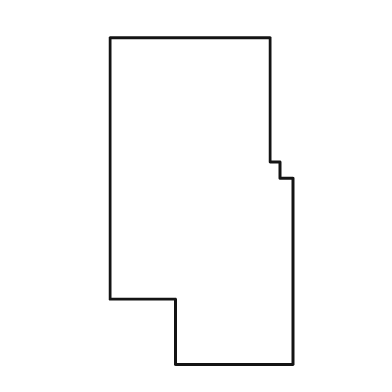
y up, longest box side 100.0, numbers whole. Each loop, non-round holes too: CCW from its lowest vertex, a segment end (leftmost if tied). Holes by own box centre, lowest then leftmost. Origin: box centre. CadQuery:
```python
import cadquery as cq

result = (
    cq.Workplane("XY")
    .moveTo(-8.0, -50.0)
    .lineTo(28.0, -50.0)
    .lineTo(28.0, 7.0)
    .lineTo(24.0, 7.0)
    .lineTo(24.0, 12.0)
    .lineTo(21.0, 12.0)
    .lineTo(21.0, 50.0)
    .lineTo(-28.0, 50.0)
    .lineTo(-28.0, -30.0)
    .lineTo(-8.0, -30.0)
    .close()
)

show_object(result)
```